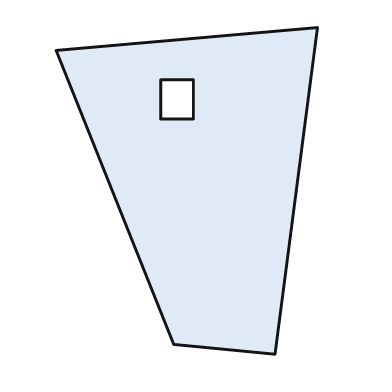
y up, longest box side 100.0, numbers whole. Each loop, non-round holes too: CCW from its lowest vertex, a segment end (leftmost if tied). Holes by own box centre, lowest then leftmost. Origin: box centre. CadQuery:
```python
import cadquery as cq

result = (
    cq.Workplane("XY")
    .moveTo(27.0, -50.0)
    .lineTo(40.0, 50.0)
    .lineTo(-40.0, 43.0)
    .lineTo(-4.0, -47.0)
    .close()
    .moveTo(-8.0, 22.0)
    .lineTo(2.0, 22.0)
    .lineTo(2.0, 34.0)
    .lineTo(-8.0, 34.0)
    .close()
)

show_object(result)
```